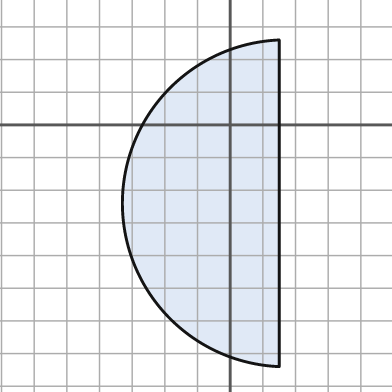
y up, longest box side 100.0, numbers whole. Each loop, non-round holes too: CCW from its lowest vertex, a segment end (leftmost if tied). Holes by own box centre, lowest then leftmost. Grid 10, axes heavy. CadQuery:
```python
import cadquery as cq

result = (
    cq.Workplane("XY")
    .moveTo(15.0, -74.0)
    .lineTo(15.0, 26.0)
    .threePointArc((-33.0, -24.0), (15.0, -74.0))
    .close()
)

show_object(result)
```